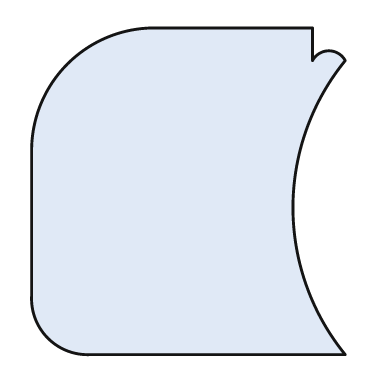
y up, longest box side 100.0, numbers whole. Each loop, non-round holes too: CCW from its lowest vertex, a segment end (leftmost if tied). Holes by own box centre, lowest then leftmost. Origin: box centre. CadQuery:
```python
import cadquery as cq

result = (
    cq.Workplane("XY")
    .moveTo(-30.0, -50.0)
    .lineTo(48.0, -50.0)
    .threePointArc((32.0, -5.0), (48.0, 40.0))
    .threePointArc((43.0, 43.0), (38.0, 40.0))
    .lineTo(38.0, 50.0)
    .lineTo(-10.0, 50.0)
    .threePointArc((-37.0, 39.0), (-48.0, 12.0))
    .lineTo(-48.0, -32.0)
    .threePointArc((-43.0, -45.0), (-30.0, -50.0))
    .close()
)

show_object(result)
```